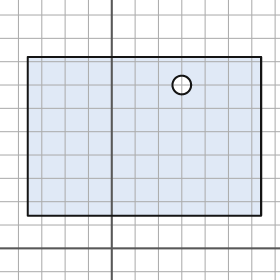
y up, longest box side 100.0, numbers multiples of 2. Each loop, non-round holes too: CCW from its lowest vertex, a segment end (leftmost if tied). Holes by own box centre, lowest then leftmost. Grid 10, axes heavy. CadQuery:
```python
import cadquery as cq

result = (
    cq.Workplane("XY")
    .moveTo(-36.0, 14.0)
    .lineTo(64.0, 14.0)
    .lineTo(64.0, 82.0)
    .lineTo(-36.0, 82.0)
    .close()
    .moveTo(30.0, 70.0)
    .circle(4.0)
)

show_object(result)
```